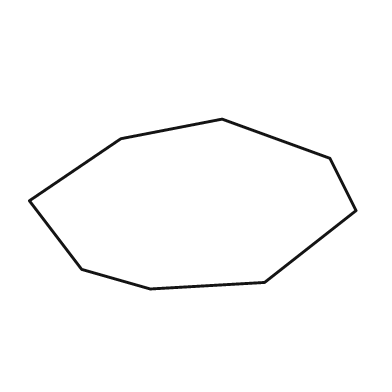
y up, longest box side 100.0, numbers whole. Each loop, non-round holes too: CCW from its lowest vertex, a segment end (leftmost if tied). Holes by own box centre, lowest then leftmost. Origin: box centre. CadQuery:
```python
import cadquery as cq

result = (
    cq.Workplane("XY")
    .moveTo(-13.0, -26.0)
    .lineTo(22.0, -24.0)
    .lineTo(50.0, -2.0)
    .lineTo(42.0, 14.0)
    .lineTo(9.0, 26.0)
    .lineTo(-22.0, 20.0)
    .lineTo(-50.0, 1.0)
    .lineTo(-34.0, -20.0)
    .close()
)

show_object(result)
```